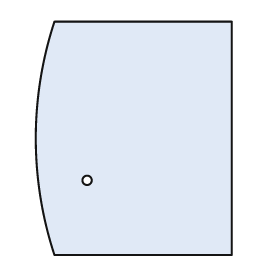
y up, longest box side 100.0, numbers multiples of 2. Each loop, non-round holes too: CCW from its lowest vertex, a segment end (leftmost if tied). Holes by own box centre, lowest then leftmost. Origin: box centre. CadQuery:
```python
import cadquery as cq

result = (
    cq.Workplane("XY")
    .moveTo(-34.0, -50.0)
    .lineTo(42.0, -50.0)
    .lineTo(42.0, 50.0)
    .lineTo(-34.0, 50.0)
    .threePointArc((-42.0, 0.0), (-34.0, -50.0))
    .close()
    .moveTo(-20.0, -18.0)
    .circle(2.0)
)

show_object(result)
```